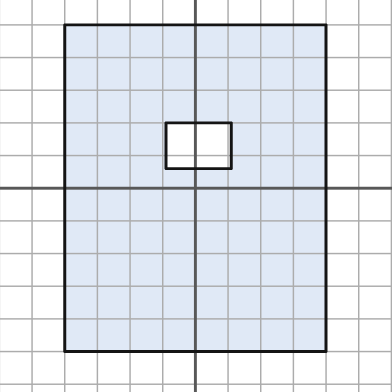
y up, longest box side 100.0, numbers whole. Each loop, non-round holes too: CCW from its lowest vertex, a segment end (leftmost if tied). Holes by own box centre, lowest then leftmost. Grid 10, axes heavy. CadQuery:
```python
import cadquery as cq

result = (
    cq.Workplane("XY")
    .moveTo(-40.0, -50.0)
    .lineTo(40.0, -50.0)
    .lineTo(40.0, 50.0)
    .lineTo(-40.0, 50.0)
    .close()
    .moveTo(-9.0, 6.0)
    .lineTo(11.0, 6.0)
    .lineTo(11.0, 20.0)
    .lineTo(-9.0, 20.0)
    .close()
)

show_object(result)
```